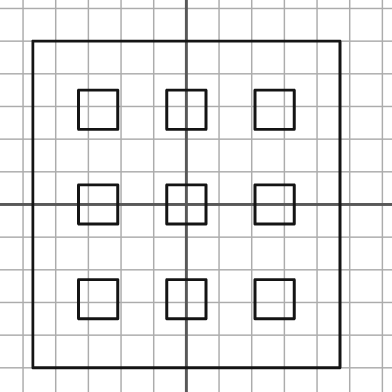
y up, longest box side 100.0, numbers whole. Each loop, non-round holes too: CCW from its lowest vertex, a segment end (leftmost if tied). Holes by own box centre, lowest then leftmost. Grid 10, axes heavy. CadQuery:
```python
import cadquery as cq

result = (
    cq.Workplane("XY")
    .moveTo(-47.0, -50.0)
    .lineTo(47.0, -50.0)
    .lineTo(47.0, 50.0)
    .lineTo(-47.0, 50.0)
    .close()
    .moveTo(-33.0, -35.0)
    .lineTo(-21.0, -35.0)
    .lineTo(-21.0, -23.0)
    .lineTo(-33.0, -23.0)
    .close()
    .moveTo(-6.0, -35.0)
    .lineTo(6.0, -35.0)
    .lineTo(6.0, -23.0)
    .lineTo(-6.0, -23.0)
    .close()
    .moveTo(21.0, -35.0)
    .lineTo(33.0, -35.0)
    .lineTo(33.0, -23.0)
    .lineTo(21.0, -23.0)
    .close()
    .moveTo(-33.0, -6.0)
    .lineTo(-21.0, -6.0)
    .lineTo(-21.0, 6.0)
    .lineTo(-33.0, 6.0)
    .close()
    .moveTo(-6.0, -6.0)
    .lineTo(6.0, -6.0)
    .lineTo(6.0, 6.0)
    .lineTo(-6.0, 6.0)
    .close()
    .moveTo(21.0, -6.0)
    .lineTo(33.0, -6.0)
    .lineTo(33.0, 6.0)
    .lineTo(21.0, 6.0)
    .close()
    .moveTo(-33.0, 23.0)
    .lineTo(-21.0, 23.0)
    .lineTo(-21.0, 35.0)
    .lineTo(-33.0, 35.0)
    .close()
    .moveTo(-6.0, 23.0)
    .lineTo(6.0, 23.0)
    .lineTo(6.0, 35.0)
    .lineTo(-6.0, 35.0)
    .close()
    .moveTo(21.0, 23.0)
    .lineTo(33.0, 23.0)
    .lineTo(33.0, 35.0)
    .lineTo(21.0, 35.0)
    .close()
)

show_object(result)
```